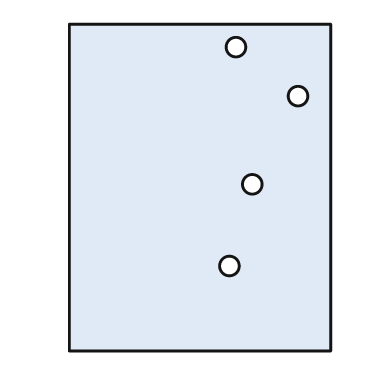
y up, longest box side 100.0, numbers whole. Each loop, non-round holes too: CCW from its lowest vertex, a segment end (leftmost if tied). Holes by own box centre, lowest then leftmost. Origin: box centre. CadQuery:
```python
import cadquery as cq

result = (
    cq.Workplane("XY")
    .moveTo(-40.0, -50.0)
    .lineTo(40.0, -50.0)
    .lineTo(40.0, 50.0)
    .lineTo(-40.0, 50.0)
    .close()
    .moveTo(9.0, -24.0)
    .circle(3.0)
    .moveTo(16.0, 1.0)
    .circle(3.0)
    .moveTo(30.0, 28.0)
    .circle(3.0)
    .moveTo(11.0, 43.0)
    .circle(3.0)
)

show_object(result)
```